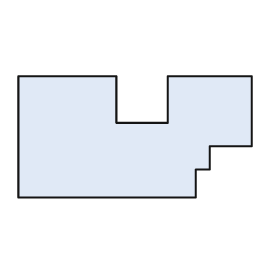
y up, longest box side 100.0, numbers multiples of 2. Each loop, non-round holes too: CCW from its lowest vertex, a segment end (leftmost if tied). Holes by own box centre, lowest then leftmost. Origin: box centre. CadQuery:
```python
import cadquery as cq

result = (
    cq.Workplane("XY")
    .moveTo(-50.0, -26.0)
    .lineTo(26.0, -26.0)
    .lineTo(26.0, -14.0)
    .lineTo(32.0, -14.0)
    .lineTo(32.0, -4.0)
    .lineTo(50.0, -4.0)
    .lineTo(50.0, 26.0)
    .lineTo(14.0, 26.0)
    .lineTo(14.0, 6.0)
    .lineTo(-8.0, 6.0)
    .lineTo(-8.0, 26.0)
    .lineTo(-50.0, 26.0)
    .close()
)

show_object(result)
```